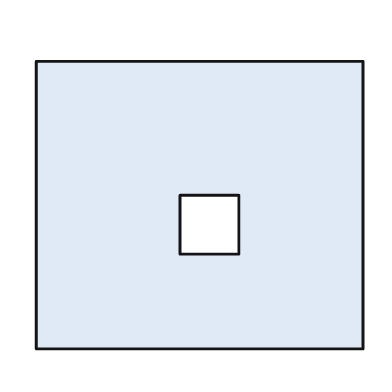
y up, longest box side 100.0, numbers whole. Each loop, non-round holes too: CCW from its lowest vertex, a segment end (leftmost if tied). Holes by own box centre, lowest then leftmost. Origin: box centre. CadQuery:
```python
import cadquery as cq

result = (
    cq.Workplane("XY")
    .moveTo(-50.0, -44.0)
    .lineTo(50.0, -44.0)
    .lineTo(50.0, 44.0)
    .lineTo(-50.0, 44.0)
    .close()
    .moveTo(-6.0, -15.0)
    .lineTo(12.0, -15.0)
    .lineTo(12.0, 3.0)
    .lineTo(-6.0, 3.0)
    .close()
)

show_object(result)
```